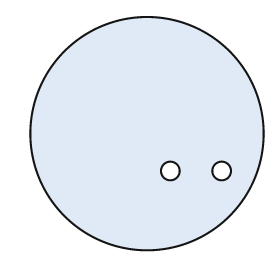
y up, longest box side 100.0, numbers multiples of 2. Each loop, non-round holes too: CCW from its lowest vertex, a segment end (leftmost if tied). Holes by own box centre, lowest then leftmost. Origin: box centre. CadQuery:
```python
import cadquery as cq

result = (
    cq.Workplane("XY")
    .moveTo(0.0, 0.0)
    .circle(50.0)
    .moveTo(10.0, -16.0)
    .circle(4.0)
    .moveTo(32.0, -16.0)
    .circle(4.0)
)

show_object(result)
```